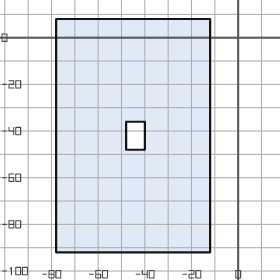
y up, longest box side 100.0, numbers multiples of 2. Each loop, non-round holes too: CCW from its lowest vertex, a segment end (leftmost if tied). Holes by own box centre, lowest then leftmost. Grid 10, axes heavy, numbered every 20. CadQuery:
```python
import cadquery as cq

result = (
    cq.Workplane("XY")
    .moveTo(-78.0, -92.0)
    .lineTo(-12.0, -92.0)
    .lineTo(-12.0, 8.0)
    .lineTo(-78.0, 8.0)
    .close()
    .moveTo(-48.0, -48.0)
    .lineTo(-40.0, -48.0)
    .lineTo(-40.0, -36.0)
    .lineTo(-48.0, -36.0)
    .close()
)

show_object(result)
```